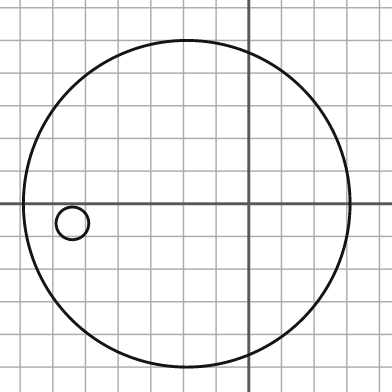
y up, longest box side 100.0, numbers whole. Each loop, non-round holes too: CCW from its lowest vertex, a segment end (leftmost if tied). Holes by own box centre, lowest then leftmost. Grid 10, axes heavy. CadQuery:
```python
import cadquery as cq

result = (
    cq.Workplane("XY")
    .moveTo(-19.0, 0.0)
    .circle(50.0)
    .moveTo(-54.0, -6.0)
    .circle(5.0)
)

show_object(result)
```